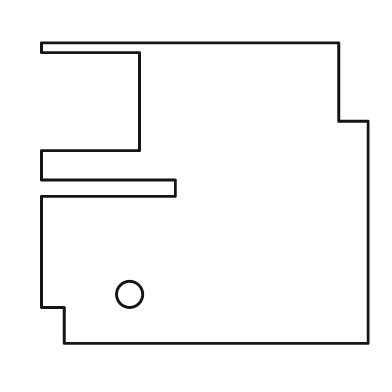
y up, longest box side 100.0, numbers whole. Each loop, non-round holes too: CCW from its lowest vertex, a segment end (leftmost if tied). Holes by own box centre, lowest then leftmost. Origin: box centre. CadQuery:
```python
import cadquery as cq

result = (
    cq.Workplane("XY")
    .moveTo(-43.0, -46.0)
    .lineTo(50.0, -46.0)
    .lineTo(50.0, 22.0)
    .lineTo(41.0, 22.0)
    .lineTo(41.0, 46.0)
    .lineTo(-50.0, 46.0)
    .lineTo(-50.0, 43.0)
    .lineTo(-20.0, 43.0)
    .lineTo(-20.0, 13.0)
    .lineTo(-50.0, 13.0)
    .lineTo(-50.0, 4.0)
    .lineTo(-9.0, 4.0)
    .lineTo(-9.0, -1.0)
    .lineTo(-50.0, -1.0)
    .lineTo(-50.0, -35.0)
    .lineTo(-43.0, -35.0)
    .close()
    .moveTo(-23.0, -31.0)
    .circle(4.0)
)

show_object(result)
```